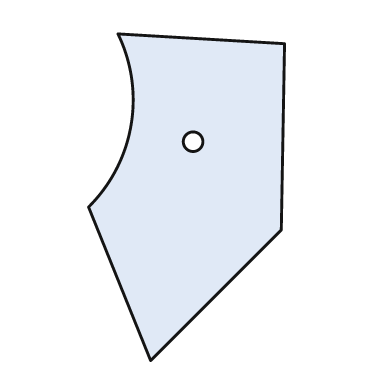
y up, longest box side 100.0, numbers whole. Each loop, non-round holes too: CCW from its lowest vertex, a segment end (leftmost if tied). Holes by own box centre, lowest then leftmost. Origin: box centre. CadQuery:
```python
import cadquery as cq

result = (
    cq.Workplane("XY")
    .moveTo(-11.0, -50.0)
    .lineTo(29.0, -10.0)
    .lineTo(30.0, 47.0)
    .lineTo(-21.0, 50.0)
    .threePointArc((-17.0, 22.0), (-30.0, -3.0))
    .close()
    .moveTo(2.0, 17.0)
    .circle(3.0)
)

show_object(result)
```